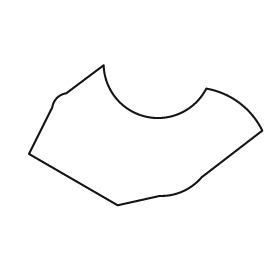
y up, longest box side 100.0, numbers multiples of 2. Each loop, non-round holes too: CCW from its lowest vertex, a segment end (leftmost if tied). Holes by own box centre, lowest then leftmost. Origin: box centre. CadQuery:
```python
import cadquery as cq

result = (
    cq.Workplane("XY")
    .moveTo(-12.0, -30.0)
    .lineTo(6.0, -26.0)
    .threePointArc((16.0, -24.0), (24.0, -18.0))
    .lineTo(50.0, 2.0)
    .threePointArc((40.0, 14.0), (26.0, 20.0))
    .threePointArc((0.0, 8.0), (-18.0, 30.0))
    .lineTo(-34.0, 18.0)
    .threePointArc((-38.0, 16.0), (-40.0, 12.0))
    .lineTo(-50.0, -8.0)
    .close()
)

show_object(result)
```